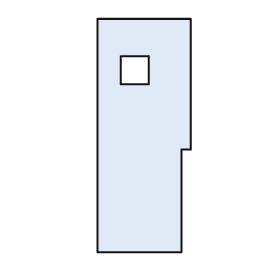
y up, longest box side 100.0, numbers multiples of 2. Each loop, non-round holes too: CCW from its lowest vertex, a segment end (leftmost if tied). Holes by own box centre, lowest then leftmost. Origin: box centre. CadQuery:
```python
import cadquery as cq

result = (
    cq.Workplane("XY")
    .moveTo(-20.0, -50.0)
    .lineTo(16.0, -50.0)
    .lineTo(16.0, -6.0)
    .lineTo(20.0, -6.0)
    .lineTo(20.0, 50.0)
    .lineTo(-20.0, 50.0)
    .close()
    .moveTo(-10.0, 22.0)
    .lineTo(2.0, 22.0)
    .lineTo(2.0, 34.0)
    .lineTo(-10.0, 34.0)
    .close()
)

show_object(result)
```